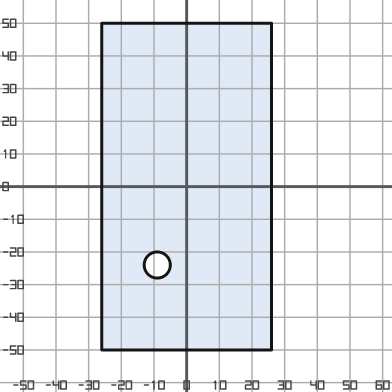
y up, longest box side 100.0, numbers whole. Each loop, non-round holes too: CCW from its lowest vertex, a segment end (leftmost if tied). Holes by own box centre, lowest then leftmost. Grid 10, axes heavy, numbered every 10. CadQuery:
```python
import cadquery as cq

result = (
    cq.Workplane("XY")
    .moveTo(-26.0, -50.0)
    .lineTo(26.0, -50.0)
    .lineTo(26.0, 50.0)
    .lineTo(-26.0, 50.0)
    .close()
    .moveTo(-9.0, -24.0)
    .circle(4.0)
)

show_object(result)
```